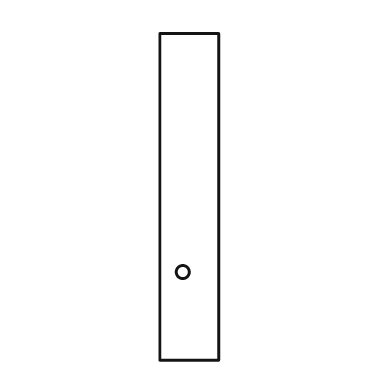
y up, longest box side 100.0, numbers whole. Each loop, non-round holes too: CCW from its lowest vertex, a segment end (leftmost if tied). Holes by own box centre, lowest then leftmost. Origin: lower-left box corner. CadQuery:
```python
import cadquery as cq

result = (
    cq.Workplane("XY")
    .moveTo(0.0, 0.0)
    .lineTo(18.0, 0.0)
    .lineTo(18.0, 100.0)
    .lineTo(0.0, 100.0)
    .close()
    .moveTo(7.0, 27.0)
    .circle(2.0)
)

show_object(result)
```